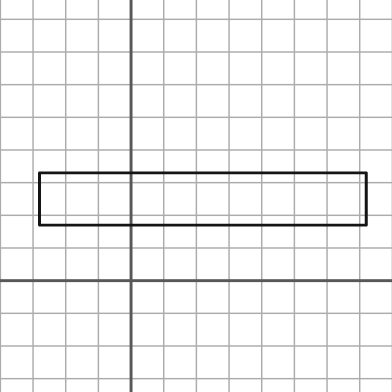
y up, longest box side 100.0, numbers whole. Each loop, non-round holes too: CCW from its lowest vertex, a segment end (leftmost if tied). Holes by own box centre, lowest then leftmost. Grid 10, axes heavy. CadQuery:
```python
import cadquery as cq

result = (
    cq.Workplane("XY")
    .moveTo(-28.0, 17.0)
    .lineTo(72.0, 17.0)
    .lineTo(72.0, 33.0)
    .lineTo(-28.0, 33.0)
    .close()
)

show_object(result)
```